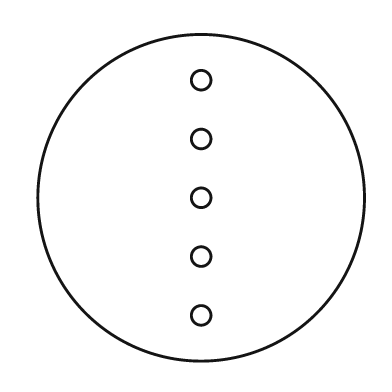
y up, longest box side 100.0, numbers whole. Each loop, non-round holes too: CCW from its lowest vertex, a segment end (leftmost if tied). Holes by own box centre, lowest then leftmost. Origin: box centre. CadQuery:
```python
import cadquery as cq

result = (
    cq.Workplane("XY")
    .moveTo(0.0, 0.0)
    .circle(50.0)
    .moveTo(0.0, -36.0)
    .circle(3.0)
    .moveTo(0.0, -18.0)
    .circle(3.0)
    .moveTo(0.0, 0.0)
    .circle(3.0)
    .moveTo(0.0, 18.0)
    .circle(3.0)
    .moveTo(0.0, 36.0)
    .circle(3.0)
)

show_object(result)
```